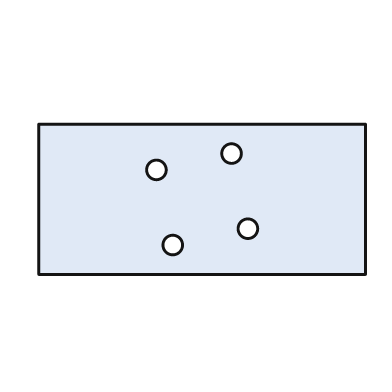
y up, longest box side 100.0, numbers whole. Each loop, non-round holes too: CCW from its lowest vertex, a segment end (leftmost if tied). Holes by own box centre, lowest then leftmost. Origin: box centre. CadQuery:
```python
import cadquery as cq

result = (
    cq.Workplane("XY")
    .moveTo(-50.0, -23.0)
    .lineTo(50.0, -23.0)
    .lineTo(50.0, 23.0)
    .lineTo(-50.0, 23.0)
    .close()
    .moveTo(-9.0, -14.0)
    .circle(3.0)
    .moveTo(14.0, -9.0)
    .circle(3.0)
    .moveTo(-14.0, 9.0)
    .circle(3.0)
    .moveTo(9.0, 14.0)
    .circle(3.0)
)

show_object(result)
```